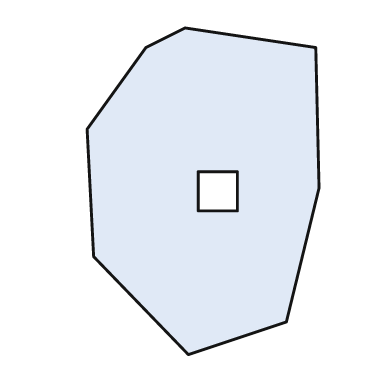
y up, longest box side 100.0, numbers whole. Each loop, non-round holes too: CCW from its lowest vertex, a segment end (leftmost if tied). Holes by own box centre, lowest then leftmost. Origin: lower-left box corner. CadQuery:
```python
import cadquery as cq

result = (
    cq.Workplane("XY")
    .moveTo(31.0, 0.0)
    .lineTo(61.0, 10.0)
    .lineTo(71.0, 51.0)
    .lineTo(70.0, 94.0)
    .lineTo(30.0, 100.0)
    .lineTo(18.0, 94.0)
    .lineTo(0.0, 69.0)
    .lineTo(2.0, 30.0)
    .close()
    .moveTo(34.0, 44.0)
    .lineTo(46.0, 44.0)
    .lineTo(46.0, 56.0)
    .lineTo(34.0, 56.0)
    .close()
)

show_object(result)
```